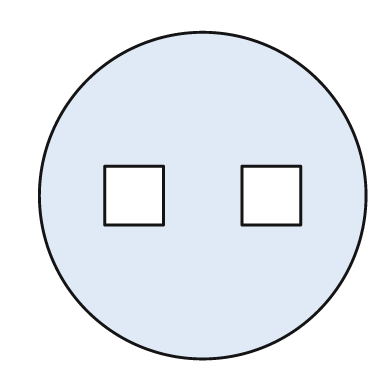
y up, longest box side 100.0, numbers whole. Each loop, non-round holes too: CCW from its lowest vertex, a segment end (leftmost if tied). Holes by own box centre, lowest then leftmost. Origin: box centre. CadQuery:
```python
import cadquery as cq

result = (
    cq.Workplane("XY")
    .moveTo(0.0, 0.0)
    .circle(50.0)
    .moveTo(-30.0, -9.0)
    .lineTo(-12.0, -9.0)
    .lineTo(-12.0, 9.0)
    .lineTo(-30.0, 9.0)
    .close()
    .moveTo(12.0, -9.0)
    .lineTo(30.0, -9.0)
    .lineTo(30.0, 9.0)
    .lineTo(12.0, 9.0)
    .close()
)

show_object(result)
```